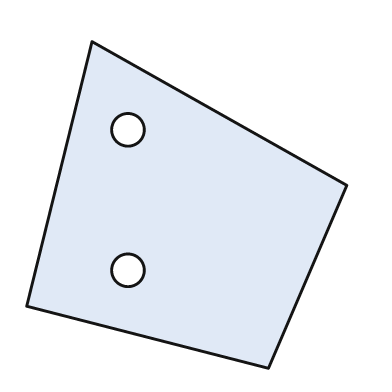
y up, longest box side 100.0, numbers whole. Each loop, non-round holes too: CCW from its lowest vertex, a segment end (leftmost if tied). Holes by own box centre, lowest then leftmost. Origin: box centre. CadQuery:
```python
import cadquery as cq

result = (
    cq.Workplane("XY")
    .moveTo(25.0, -50.0)
    .lineTo(49.0, 6.0)
    .lineTo(-29.0, 50.0)
    .lineTo(-49.0, -31.0)
    .close()
    .moveTo(-18.0, -20.0)
    .circle(5.0)
    .moveTo(-18.0, 23.0)
    .circle(5.0)
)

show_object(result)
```